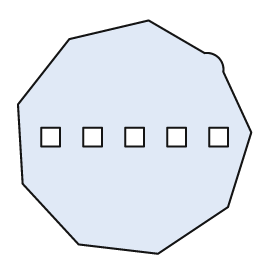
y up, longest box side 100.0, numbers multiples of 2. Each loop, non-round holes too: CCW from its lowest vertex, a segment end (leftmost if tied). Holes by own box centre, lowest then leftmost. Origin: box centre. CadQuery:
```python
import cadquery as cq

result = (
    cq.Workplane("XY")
    .moveTo(10.0, -50.0)
    .lineTo(40.0, -30.0)
    .lineTo(50.0, 2.0)
    .lineTo(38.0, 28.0)
    .threePointArc((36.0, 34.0), (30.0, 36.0))
    .lineTo(6.0, 50.0)
    .lineTo(-28.0, 42.0)
    .lineTo(-50.0, 14.0)
    .lineTo(-48.0, -20.0)
    .lineTo(-24.0, -46.0)
    .close()
    .moveTo(-40.0, -4.0)
    .lineTo(-32.0, -4.0)
    .lineTo(-32.0, 4.0)
    .lineTo(-40.0, 4.0)
    .close()
    .moveTo(-22.0, -4.0)
    .lineTo(-14.0, -4.0)
    .lineTo(-14.0, 4.0)
    .lineTo(-22.0, 4.0)
    .close()
    .moveTo(-4.0, -4.0)
    .lineTo(4.0, -4.0)
    .lineTo(4.0, 4.0)
    .lineTo(-4.0, 4.0)
    .close()
    .moveTo(14.0, -4.0)
    .lineTo(22.0, -4.0)
    .lineTo(22.0, 4.0)
    .lineTo(14.0, 4.0)
    .close()
    .moveTo(32.0, -4.0)
    .lineTo(40.0, -4.0)
    .lineTo(40.0, 4.0)
    .lineTo(32.0, 4.0)
    .close()
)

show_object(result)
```